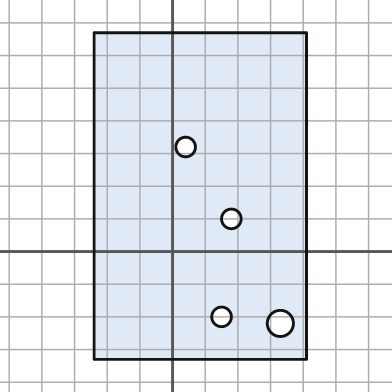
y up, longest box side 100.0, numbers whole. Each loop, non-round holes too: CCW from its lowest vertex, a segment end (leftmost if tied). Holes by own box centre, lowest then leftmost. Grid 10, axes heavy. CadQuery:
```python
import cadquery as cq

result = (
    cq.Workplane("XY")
    .moveTo(-24.0, -33.0)
    .lineTo(41.0, -33.0)
    .lineTo(41.0, 67.0)
    .lineTo(-24.0, 67.0)
    .close()
    .moveTo(33.0, -22.0)
    .circle(4.0)
    .moveTo(15.0, -20.0)
    .circle(3.0)
    .moveTo(18.0, 10.0)
    .circle(3.0)
    .moveTo(4.0, 32.0)
    .circle(3.0)
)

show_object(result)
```